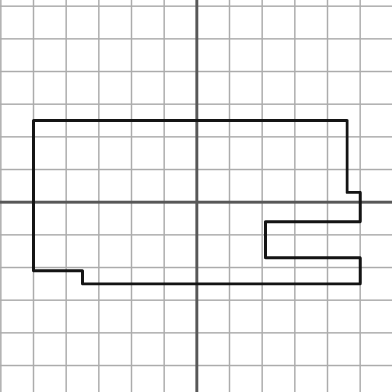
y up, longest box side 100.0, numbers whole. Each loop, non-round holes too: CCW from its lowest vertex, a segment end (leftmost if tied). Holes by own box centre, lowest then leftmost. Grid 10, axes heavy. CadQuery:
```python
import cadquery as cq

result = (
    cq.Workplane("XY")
    .moveTo(-35.0, -25.0)
    .lineTo(50.0, -25.0)
    .lineTo(50.0, -17.0)
    .lineTo(21.0, -17.0)
    .lineTo(21.0, -6.0)
    .lineTo(50.0, -6.0)
    .lineTo(50.0, 3.0)
    .lineTo(46.0, 3.0)
    .lineTo(46.0, 25.0)
    .lineTo(-50.0, 25.0)
    .lineTo(-50.0, -21.0)
    .lineTo(-35.0, -21.0)
    .close()
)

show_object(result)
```